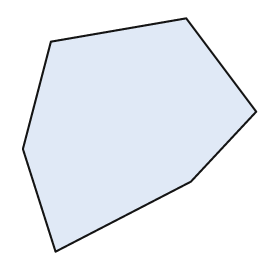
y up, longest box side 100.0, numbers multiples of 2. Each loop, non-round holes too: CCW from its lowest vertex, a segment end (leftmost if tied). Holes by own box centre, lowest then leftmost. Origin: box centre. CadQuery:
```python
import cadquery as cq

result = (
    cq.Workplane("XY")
    .moveTo(-36.0, -50.0)
    .lineTo(22.0, -20.0)
    .lineTo(50.0, 10.0)
    .lineTo(20.0, 50.0)
    .lineTo(-38.0, 40.0)
    .lineTo(-50.0, -6.0)
    .close()
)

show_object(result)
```